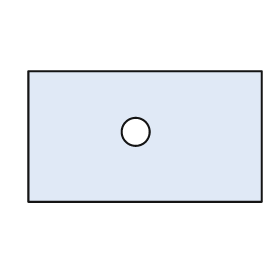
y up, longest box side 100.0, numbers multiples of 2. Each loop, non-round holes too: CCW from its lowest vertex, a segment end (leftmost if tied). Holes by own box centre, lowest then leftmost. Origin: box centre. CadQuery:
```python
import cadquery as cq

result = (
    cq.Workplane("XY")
    .moveTo(-50.0, -28.0)
    .lineTo(50.0, -28.0)
    .lineTo(50.0, 28.0)
    .lineTo(-50.0, 28.0)
    .close()
    .moveTo(-4.0, 2.0)
    .circle(6.0)
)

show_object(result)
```